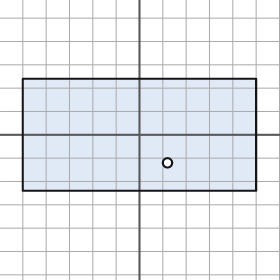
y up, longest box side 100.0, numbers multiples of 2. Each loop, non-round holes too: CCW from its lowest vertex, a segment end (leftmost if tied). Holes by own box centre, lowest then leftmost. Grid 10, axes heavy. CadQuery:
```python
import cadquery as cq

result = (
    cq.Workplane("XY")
    .moveTo(-50.0, -24.0)
    .lineTo(50.0, -24.0)
    .lineTo(50.0, 24.0)
    .lineTo(-50.0, 24.0)
    .close()
    .moveTo(12.0, -12.0)
    .circle(2.0)
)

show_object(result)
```